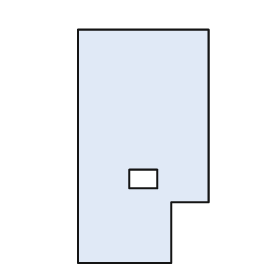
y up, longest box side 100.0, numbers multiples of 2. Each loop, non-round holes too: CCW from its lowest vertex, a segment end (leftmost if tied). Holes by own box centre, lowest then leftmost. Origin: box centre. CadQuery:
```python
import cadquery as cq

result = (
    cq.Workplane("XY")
    .moveTo(-28.0, -50.0)
    .lineTo(12.0, -50.0)
    .lineTo(12.0, -24.0)
    .lineTo(28.0, -24.0)
    .lineTo(28.0, 50.0)
    .lineTo(-28.0, 50.0)
    .close()
    .moveTo(-6.0, -18.0)
    .lineTo(6.0, -18.0)
    .lineTo(6.0, -10.0)
    .lineTo(-6.0, -10.0)
    .close()
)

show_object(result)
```